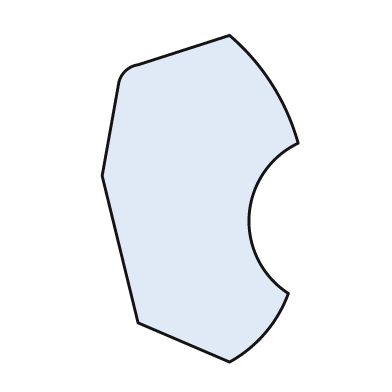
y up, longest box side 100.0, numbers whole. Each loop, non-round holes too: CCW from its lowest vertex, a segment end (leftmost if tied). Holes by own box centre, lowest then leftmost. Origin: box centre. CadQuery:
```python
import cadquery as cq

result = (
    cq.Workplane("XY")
    .moveTo(9.0, -50.0)
    .threePointArc((20.0, -41.0), (27.0, -29.0))
    .threePointArc((15.0, -5.0), (30.0, 17.0))
    .threePointArc((22.0, 35.0), (9.0, 50.0))
    .lineTo(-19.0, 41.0)
    .threePointArc((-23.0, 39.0), (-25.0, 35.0))
    .lineTo(-30.0, 7.0)
    .lineTo(-19.0, -38.0)
    .close()
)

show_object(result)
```